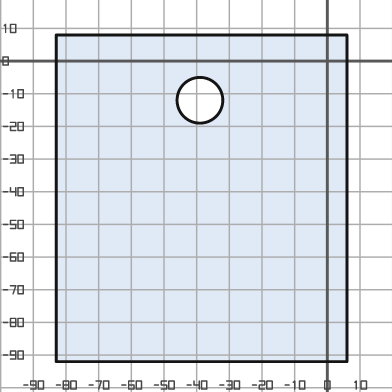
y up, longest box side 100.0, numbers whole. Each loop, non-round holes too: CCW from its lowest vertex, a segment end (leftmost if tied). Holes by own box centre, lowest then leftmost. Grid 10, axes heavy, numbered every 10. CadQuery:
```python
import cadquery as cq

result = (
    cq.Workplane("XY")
    .moveTo(-83.0, -92.0)
    .lineTo(6.0, -92.0)
    .lineTo(6.0, 8.0)
    .lineTo(-83.0, 8.0)
    .close()
    .moveTo(-39.0, -12.0)
    .circle(7.0)
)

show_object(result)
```